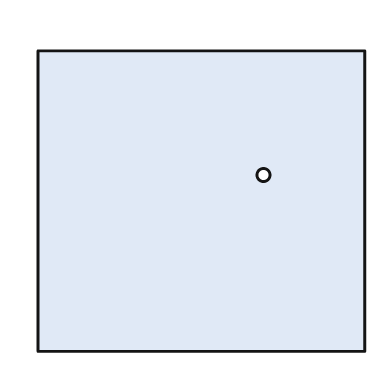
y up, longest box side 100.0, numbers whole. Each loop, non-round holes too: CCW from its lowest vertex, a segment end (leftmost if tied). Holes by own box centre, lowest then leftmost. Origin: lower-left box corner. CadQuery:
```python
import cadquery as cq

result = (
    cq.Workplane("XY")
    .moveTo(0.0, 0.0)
    .lineTo(100.0, 0.0)
    .lineTo(100.0, 92.0)
    .lineTo(0.0, 92.0)
    .close()
    .moveTo(69.0, 54.0)
    .circle(2.0)
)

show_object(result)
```